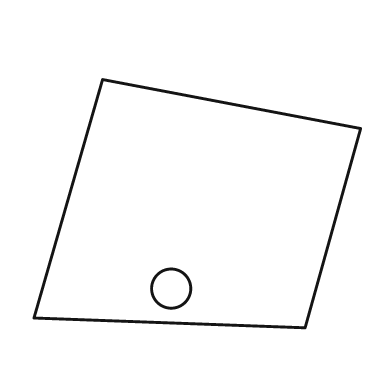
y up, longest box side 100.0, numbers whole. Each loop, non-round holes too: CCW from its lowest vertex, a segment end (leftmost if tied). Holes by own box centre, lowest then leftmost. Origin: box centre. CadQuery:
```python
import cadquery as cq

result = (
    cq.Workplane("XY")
    .moveTo(33.0, -38.0)
    .lineTo(50.0, 23.0)
    .lineTo(-29.0, 38.0)
    .lineTo(-50.0, -35.0)
    .close()
    .moveTo(-8.0, -26.0)
    .circle(6.0)
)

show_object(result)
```